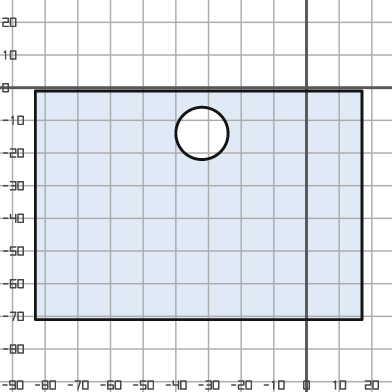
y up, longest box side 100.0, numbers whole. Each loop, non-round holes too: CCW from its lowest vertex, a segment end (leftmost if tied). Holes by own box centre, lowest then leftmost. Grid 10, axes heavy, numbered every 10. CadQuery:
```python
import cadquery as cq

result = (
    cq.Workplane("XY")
    .moveTo(-83.0, -71.0)
    .lineTo(17.0, -71.0)
    .lineTo(17.0, -1.0)
    .lineTo(-83.0, -1.0)
    .close()
    .moveTo(-32.0, -14.0)
    .circle(8.0)
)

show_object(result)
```